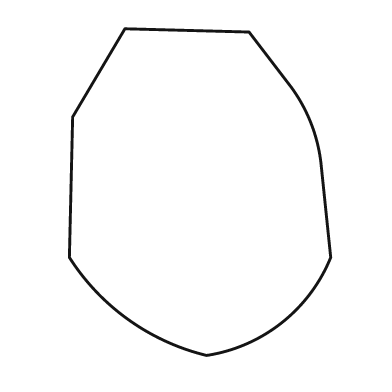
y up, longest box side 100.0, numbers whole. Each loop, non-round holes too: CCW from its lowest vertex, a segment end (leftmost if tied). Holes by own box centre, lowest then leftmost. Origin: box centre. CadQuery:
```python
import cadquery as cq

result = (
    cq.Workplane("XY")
    .moveTo(2.0, -50.0)
    .threePointArc((25.0, -40.0), (40.0, -20.0))
    .lineTo(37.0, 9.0)
    .threePointArc((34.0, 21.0), (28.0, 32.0))
    .lineTo(15.0, 49.0)
    .lineTo(-23.0, 50.0)
    .lineTo(-39.0, 23.0)
    .lineTo(-40.0, -20.0)
    .threePointArc((-22.0, -39.0), (2.0, -50.0))
    .close()
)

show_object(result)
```